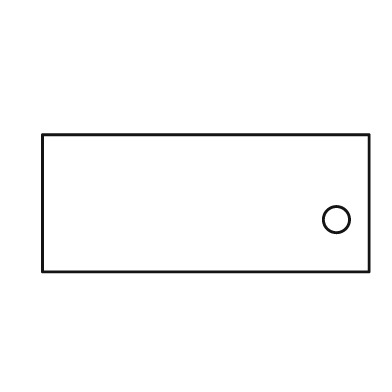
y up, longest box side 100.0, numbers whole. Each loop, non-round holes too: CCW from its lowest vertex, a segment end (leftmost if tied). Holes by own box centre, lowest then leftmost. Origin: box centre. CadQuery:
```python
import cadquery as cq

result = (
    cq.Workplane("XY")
    .moveTo(-50.0, -21.0)
    .lineTo(50.0, -21.0)
    .lineTo(50.0, 21.0)
    .lineTo(-50.0, 21.0)
    .close()
    .moveTo(40.0, -5.0)
    .circle(4.0)
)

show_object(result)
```